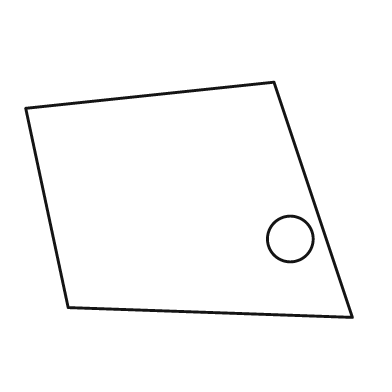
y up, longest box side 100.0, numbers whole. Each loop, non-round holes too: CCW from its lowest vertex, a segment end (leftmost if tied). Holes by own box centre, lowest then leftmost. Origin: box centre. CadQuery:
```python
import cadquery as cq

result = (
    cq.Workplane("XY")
    .moveTo(50.0, -36.0)
    .lineTo(26.0, 36.0)
    .lineTo(-50.0, 28.0)
    .lineTo(-37.0, -33.0)
    .close()
    .moveTo(31.0, -12.0)
    .circle(7.0)
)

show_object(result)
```